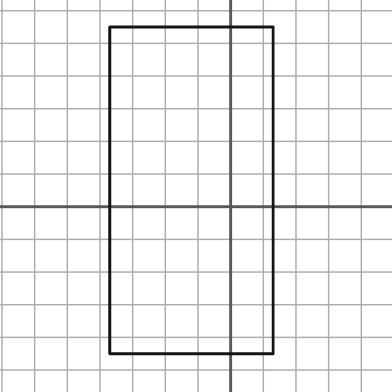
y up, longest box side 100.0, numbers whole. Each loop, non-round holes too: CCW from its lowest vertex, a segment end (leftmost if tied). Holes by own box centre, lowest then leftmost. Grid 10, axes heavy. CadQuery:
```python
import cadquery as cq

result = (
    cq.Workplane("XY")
    .moveTo(-37.0, -45.0)
    .lineTo(13.0, -45.0)
    .lineTo(13.0, 55.0)
    .lineTo(-37.0, 55.0)
    .close()
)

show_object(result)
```